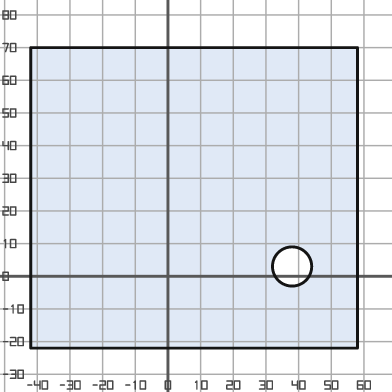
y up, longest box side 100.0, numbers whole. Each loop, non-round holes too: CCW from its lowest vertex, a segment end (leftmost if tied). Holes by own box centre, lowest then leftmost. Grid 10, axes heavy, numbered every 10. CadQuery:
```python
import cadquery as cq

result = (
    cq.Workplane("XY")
    .moveTo(-42.0, -22.0)
    .lineTo(58.0, -22.0)
    .lineTo(58.0, 70.0)
    .lineTo(-42.0, 70.0)
    .close()
    .moveTo(38.0, 3.0)
    .circle(6.0)
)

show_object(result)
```